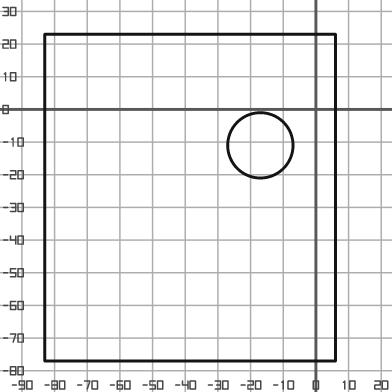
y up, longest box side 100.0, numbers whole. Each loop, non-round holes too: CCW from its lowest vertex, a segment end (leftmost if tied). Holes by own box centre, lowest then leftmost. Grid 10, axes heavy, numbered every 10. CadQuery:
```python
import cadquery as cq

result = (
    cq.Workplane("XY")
    .moveTo(-83.0, -77.0)
    .lineTo(6.0, -77.0)
    .lineTo(6.0, 23.0)
    .lineTo(-83.0, 23.0)
    .close()
    .moveTo(-17.0, -11.0)
    .circle(10.0)
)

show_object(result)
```